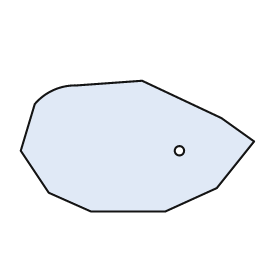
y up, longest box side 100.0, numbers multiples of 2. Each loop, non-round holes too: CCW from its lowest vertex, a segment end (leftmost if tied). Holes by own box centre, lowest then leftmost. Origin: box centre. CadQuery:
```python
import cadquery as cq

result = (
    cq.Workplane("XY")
    .moveTo(-20.0, -28.0)
    .lineTo(12.0, -28.0)
    .lineTo(34.0, -18.0)
    .lineTo(50.0, 2.0)
    .lineTo(36.0, 12.0)
    .lineTo(2.0, 28.0)
    .lineTo(-26.0, 26.0)
    .threePointArc((-36.0, 24.0), (-44.0, 18.0))
    .lineTo(-50.0, -2.0)
    .lineTo(-38.0, -20.0)
    .close()
    .moveTo(18.0, -2.0)
    .circle(2.0)
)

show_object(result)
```